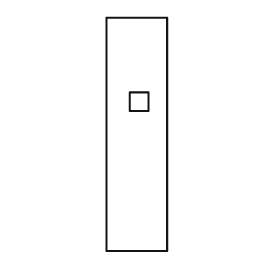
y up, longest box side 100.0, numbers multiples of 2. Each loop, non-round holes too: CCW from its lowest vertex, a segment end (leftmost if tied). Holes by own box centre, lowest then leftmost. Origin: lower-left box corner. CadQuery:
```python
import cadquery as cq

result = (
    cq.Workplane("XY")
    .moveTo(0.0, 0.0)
    .lineTo(26.0, 0.0)
    .lineTo(26.0, 100.0)
    .lineTo(0.0, 100.0)
    .close()
    .moveTo(10.0, 60.0)
    .lineTo(18.0, 60.0)
    .lineTo(18.0, 68.0)
    .lineTo(10.0, 68.0)
    .close()
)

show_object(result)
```